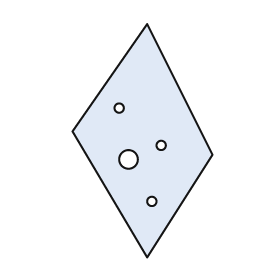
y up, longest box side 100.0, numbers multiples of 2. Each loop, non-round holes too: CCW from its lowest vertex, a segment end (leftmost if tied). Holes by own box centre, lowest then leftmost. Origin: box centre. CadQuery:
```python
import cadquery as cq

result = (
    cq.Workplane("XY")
    .moveTo(2.0, -50.0)
    .lineTo(30.0, -6.0)
    .lineTo(2.0, 50.0)
    .lineTo(-30.0, 4.0)
    .close()
    .moveTo(4.0, -26.0)
    .circle(2.0)
    .moveTo(-6.0, -8.0)
    .circle(4.0)
    .moveTo(8.0, -2.0)
    .circle(2.0)
    .moveTo(-10.0, 14.0)
    .circle(2.0)
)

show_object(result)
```